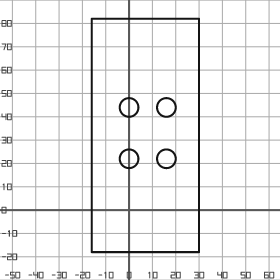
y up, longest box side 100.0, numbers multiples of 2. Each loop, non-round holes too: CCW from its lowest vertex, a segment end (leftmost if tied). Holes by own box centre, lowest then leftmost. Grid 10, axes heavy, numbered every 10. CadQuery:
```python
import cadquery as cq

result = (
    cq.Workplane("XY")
    .moveTo(-16.0, -18.0)
    .lineTo(30.0, -18.0)
    .lineTo(30.0, 82.0)
    .lineTo(-16.0, 82.0)
    .close()
    .moveTo(0.0, 22.0)
    .circle(4.0)
    .moveTo(16.0, 22.0)
    .circle(4.0)
    .moveTo(0.0, 44.0)
    .circle(4.0)
    .moveTo(16.0, 44.0)
    .circle(4.0)
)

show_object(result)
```